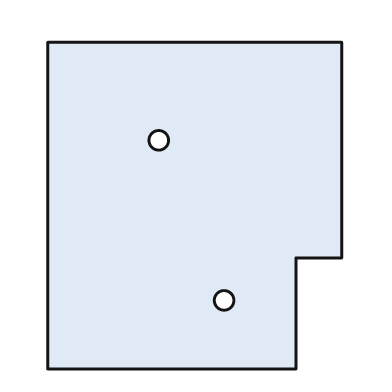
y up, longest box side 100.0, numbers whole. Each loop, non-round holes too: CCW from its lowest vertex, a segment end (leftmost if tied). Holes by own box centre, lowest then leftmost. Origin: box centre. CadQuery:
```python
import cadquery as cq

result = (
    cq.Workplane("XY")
    .moveTo(-45.0, -50.0)
    .lineTo(31.0, -50.0)
    .lineTo(31.0, -16.0)
    .lineTo(45.0, -16.0)
    .lineTo(45.0, 50.0)
    .lineTo(-45.0, 50.0)
    .close()
    .moveTo(9.0, -29.0)
    .circle(3.0)
    .moveTo(-11.0, 20.0)
    .circle(3.0)
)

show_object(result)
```